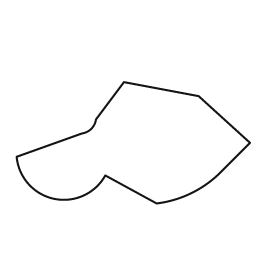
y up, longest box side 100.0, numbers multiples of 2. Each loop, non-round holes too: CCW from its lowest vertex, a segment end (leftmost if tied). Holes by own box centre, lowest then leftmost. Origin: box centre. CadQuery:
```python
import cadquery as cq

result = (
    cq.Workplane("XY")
    .moveTo(10.0, -26.0)
    .threePointArc((24.0, -22.0), (36.0, -14.0))
    .lineTo(50.0, 0.0)
    .lineTo(28.0, 20.0)
    .lineTo(-4.0, 26.0)
    .lineTo(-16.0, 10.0)
    .threePointArc((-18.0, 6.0), (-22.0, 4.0))
    .lineTo(-50.0, -6.0)
    .threePointArc((-34.0, -24.0), (-12.0, -14.0))
    .close()
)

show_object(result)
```